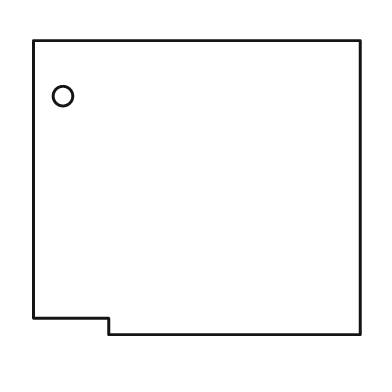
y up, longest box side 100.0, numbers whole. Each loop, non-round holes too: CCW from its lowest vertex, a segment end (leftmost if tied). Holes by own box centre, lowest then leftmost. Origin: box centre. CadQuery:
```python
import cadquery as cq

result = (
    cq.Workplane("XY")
    .moveTo(-27.0, -45.0)
    .lineTo(50.0, -45.0)
    .lineTo(50.0, 45.0)
    .lineTo(-50.0, 45.0)
    .lineTo(-50.0, -40.0)
    .lineTo(-27.0, -40.0)
    .close()
    .moveTo(-41.0, 28.0)
    .circle(3.0)
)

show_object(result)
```